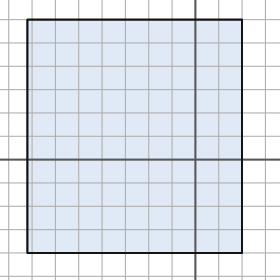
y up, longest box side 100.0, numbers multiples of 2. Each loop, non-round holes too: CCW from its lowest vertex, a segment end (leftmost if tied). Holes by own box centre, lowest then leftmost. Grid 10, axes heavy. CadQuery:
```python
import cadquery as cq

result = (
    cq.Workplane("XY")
    .moveTo(-72.0, -40.0)
    .lineTo(20.0, -40.0)
    .lineTo(20.0, 60.0)
    .lineTo(-72.0, 60.0)
    .close()
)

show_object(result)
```